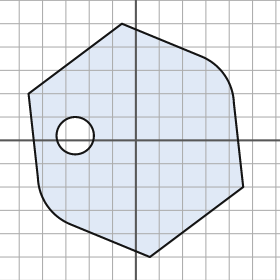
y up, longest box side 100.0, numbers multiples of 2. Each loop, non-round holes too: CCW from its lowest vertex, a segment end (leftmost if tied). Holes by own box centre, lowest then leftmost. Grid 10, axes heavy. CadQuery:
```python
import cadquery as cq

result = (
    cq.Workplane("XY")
    .moveTo(6.0, -50.0)
    .lineTo(46.0, -20.0)
    .lineTo(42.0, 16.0)
    .threePointArc((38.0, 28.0), (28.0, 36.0))
    .lineTo(-6.0, 50.0)
    .lineTo(-46.0, 20.0)
    .lineTo(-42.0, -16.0)
    .threePointArc((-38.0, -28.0), (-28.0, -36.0))
    .close()
    .moveTo(-26.0, 2.0)
    .circle(8.0)
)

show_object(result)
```